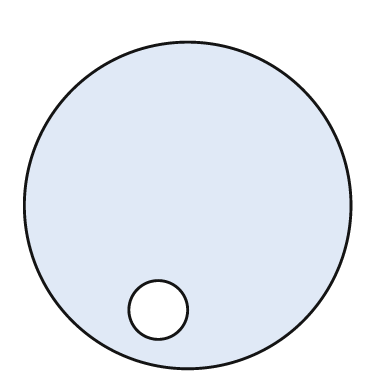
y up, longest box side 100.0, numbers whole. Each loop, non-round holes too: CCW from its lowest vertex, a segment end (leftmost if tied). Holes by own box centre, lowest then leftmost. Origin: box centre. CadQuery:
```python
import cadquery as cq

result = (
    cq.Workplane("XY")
    .moveTo(0.0, 0.0)
    .circle(50.0)
    .moveTo(-9.0, -32.0)
    .circle(9.0)
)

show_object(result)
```